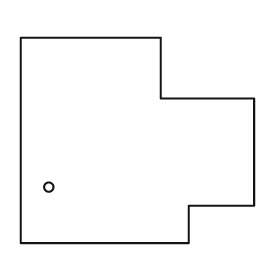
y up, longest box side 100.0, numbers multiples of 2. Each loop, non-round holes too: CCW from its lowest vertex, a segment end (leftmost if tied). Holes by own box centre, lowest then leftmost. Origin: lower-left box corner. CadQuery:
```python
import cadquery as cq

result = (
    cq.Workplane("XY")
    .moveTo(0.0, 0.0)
    .lineTo(72.0, 0.0)
    .lineTo(72.0, 16.0)
    .lineTo(100.0, 16.0)
    .lineTo(100.0, 62.0)
    .lineTo(60.0, 62.0)
    .lineTo(60.0, 88.0)
    .lineTo(0.0, 88.0)
    .close()
    .moveTo(12.0, 24.0)
    .circle(2.0)
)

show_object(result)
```